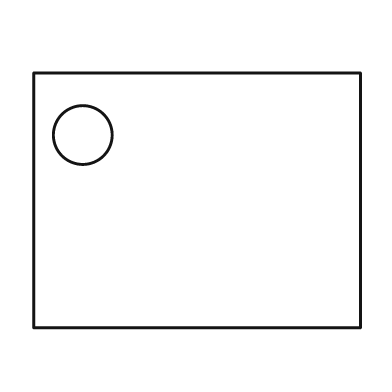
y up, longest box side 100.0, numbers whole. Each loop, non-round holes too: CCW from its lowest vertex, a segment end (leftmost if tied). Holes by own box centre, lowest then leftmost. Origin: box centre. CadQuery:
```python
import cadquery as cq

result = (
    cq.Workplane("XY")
    .moveTo(-50.0, -39.0)
    .lineTo(50.0, -39.0)
    .lineTo(50.0, 39.0)
    .lineTo(-50.0, 39.0)
    .close()
    .moveTo(-35.0, 20.0)
    .circle(9.0)
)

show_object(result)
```